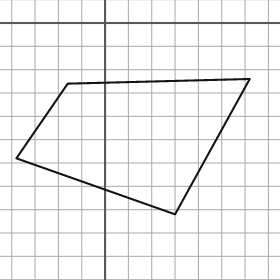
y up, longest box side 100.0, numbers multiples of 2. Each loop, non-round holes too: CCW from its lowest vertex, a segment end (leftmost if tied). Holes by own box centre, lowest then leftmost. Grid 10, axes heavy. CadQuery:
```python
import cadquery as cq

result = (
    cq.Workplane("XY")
    .moveTo(30.0, -82.0)
    .lineTo(62.0, -24.0)
    .lineTo(-16.0, -26.0)
    .lineTo(-38.0, -58.0)
    .close()
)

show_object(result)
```